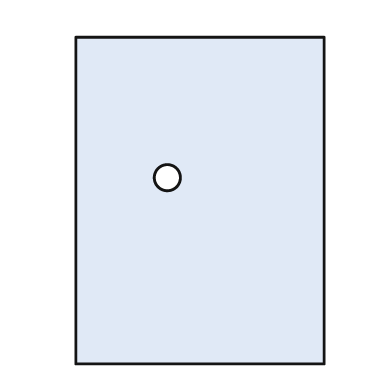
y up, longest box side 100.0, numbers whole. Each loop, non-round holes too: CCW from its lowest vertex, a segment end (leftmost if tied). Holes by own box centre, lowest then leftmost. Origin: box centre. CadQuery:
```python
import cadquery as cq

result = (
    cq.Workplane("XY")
    .moveTo(-38.0, -50.0)
    .lineTo(38.0, -50.0)
    .lineTo(38.0, 50.0)
    .lineTo(-38.0, 50.0)
    .close()
    .moveTo(-10.0, 7.0)
    .circle(4.0)
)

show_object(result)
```